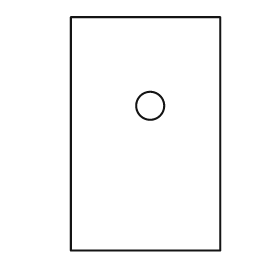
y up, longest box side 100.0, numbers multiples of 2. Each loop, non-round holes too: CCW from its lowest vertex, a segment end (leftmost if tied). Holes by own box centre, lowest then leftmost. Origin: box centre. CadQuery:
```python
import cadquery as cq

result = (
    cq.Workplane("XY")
    .moveTo(-32.0, -50.0)
    .lineTo(32.0, -50.0)
    .lineTo(32.0, 50.0)
    .lineTo(-32.0, 50.0)
    .close()
    .moveTo(2.0, 12.0)
    .circle(6.0)
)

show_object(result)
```